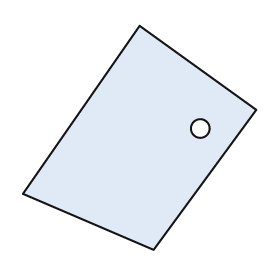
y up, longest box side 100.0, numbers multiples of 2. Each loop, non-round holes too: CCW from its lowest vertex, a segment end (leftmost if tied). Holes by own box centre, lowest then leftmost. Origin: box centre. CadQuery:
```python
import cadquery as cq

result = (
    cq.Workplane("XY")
    .moveTo(6.0, -48.0)
    .lineTo(50.0, 12.0)
    .lineTo(0.0, 48.0)
    .lineTo(-50.0, -24.0)
    .close()
    .moveTo(26.0, 4.0)
    .circle(4.0)
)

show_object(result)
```